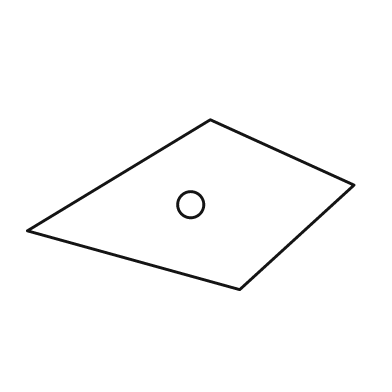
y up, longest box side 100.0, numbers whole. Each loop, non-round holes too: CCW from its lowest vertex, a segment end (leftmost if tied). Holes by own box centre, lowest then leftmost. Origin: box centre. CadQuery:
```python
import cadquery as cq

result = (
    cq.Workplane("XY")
    .moveTo(15.0, -26.0)
    .lineTo(50.0, 6.0)
    .lineTo(6.0, 26.0)
    .lineTo(-50.0, -8.0)
    .close()
    .moveTo(0.0, 0.0)
    .circle(4.0)
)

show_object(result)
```